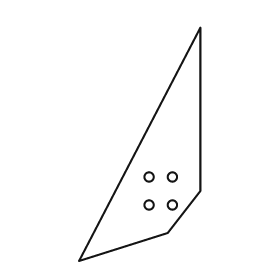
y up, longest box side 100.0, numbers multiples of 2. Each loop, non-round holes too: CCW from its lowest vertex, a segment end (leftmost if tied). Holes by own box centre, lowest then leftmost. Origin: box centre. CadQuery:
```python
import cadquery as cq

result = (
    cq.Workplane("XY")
    .moveTo(-26.0, -50.0)
    .lineTo(12.0, -38.0)
    .lineTo(26.0, -20.0)
    .lineTo(26.0, 50.0)
    .close()
    .moveTo(4.0, -26.0)
    .circle(2.0)
    .moveTo(14.0, -26.0)
    .circle(2.0)
    .moveTo(4.0, -14.0)
    .circle(2.0)
    .moveTo(14.0, -14.0)
    .circle(2.0)
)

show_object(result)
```